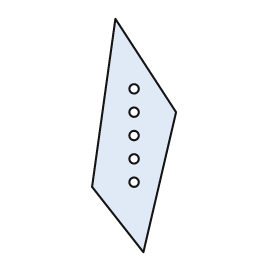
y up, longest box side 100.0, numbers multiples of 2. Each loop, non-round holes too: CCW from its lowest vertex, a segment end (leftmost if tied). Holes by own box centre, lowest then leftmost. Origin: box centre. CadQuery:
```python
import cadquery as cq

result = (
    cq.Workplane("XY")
    .moveTo(4.0, -50.0)
    .lineTo(18.0, 10.0)
    .lineTo(-8.0, 50.0)
    .lineTo(-18.0, -22.0)
    .close()
    .moveTo(0.0, -20.0)
    .circle(2.0)
    .moveTo(0.0, -10.0)
    .circle(2.0)
    .moveTo(0.0, 0.0)
    .circle(2.0)
    .moveTo(0.0, 10.0)
    .circle(2.0)
    .moveTo(0.0, 20.0)
    .circle(2.0)
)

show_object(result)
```